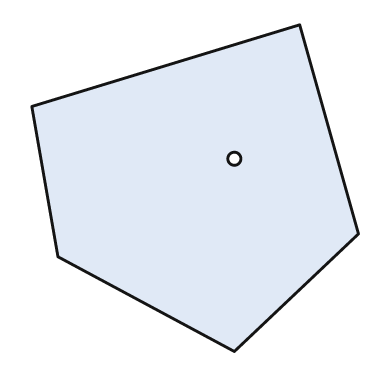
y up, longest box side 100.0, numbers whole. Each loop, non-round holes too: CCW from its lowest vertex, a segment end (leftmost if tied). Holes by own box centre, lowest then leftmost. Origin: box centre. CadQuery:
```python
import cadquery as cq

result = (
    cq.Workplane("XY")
    .moveTo(12.0, -50.0)
    .lineTo(50.0, -14.0)
    .lineTo(32.0, 50.0)
    .lineTo(-50.0, 25.0)
    .lineTo(-42.0, -21.0)
    .close()
    .moveTo(12.0, 9.0)
    .circle(2.0)
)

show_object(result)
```